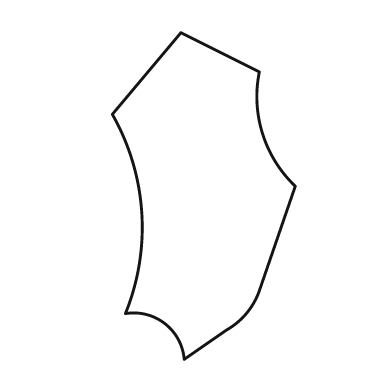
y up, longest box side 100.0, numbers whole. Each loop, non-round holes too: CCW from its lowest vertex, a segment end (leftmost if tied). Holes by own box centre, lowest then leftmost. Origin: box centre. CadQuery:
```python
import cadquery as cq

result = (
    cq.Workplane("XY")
    .moveTo(-6.0, -50.0)
    .lineTo(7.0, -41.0)
    .threePointArc((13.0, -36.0), (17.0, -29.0))
    .lineTo(28.0, 3.0)
    .threePointArc((18.0, 19.0), (17.0, 38.0))
    .lineTo(-7.0, 50.0)
    .lineTo(-28.0, 25.0)
    .threePointArc((-19.0, -5.0), (-24.0, -36.0))
    .threePointArc((-12.0, -39.0), (-6.0, -50.0))
    .close()
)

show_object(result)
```